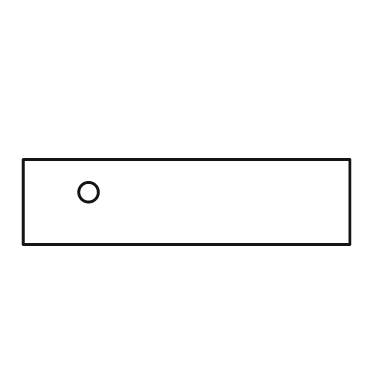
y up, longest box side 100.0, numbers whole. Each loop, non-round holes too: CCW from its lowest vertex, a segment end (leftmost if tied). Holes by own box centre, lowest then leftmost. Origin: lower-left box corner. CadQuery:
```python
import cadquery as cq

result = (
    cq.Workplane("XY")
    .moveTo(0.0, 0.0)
    .lineTo(100.0, 0.0)
    .lineTo(100.0, 26.0)
    .lineTo(0.0, 26.0)
    .close()
    .moveTo(20.0, 16.0)
    .circle(3.0)
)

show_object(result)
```